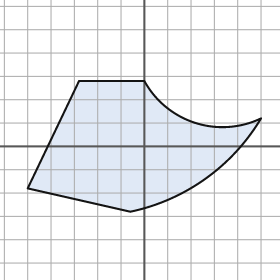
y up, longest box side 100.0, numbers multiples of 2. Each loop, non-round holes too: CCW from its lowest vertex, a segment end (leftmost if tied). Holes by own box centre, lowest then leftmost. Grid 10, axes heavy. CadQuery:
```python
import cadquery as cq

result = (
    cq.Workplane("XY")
    .moveTo(-6.0, -28.0)
    .threePointArc((26.0, -14.0), (50.0, 12.0))
    .threePointArc((22.0, 10.0), (0.0, 28.0))
    .lineTo(-28.0, 28.0)
    .lineTo(-50.0, -18.0)
    .close()
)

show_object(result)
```